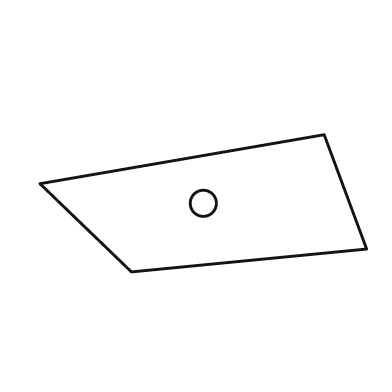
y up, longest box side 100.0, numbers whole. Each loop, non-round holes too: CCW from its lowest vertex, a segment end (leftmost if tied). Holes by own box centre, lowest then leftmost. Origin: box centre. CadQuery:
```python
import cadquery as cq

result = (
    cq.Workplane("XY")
    .moveTo(-22.0, -21.0)
    .lineTo(50.0, -14.0)
    .lineTo(37.0, 21.0)
    .lineTo(-50.0, 6.0)
    .close()
    .moveTo(0.0, 0.0)
    .circle(4.0)
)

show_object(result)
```